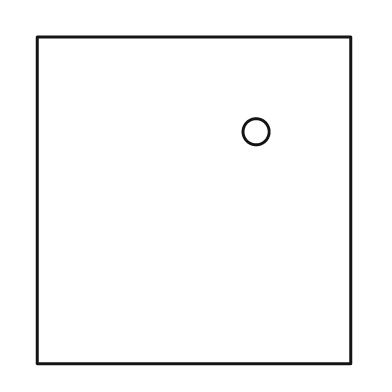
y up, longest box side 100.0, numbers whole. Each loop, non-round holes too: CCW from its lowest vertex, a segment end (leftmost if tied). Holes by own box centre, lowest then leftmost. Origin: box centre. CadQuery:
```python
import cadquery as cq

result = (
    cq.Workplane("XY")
    .moveTo(-48.0, -50.0)
    .lineTo(48.0, -50.0)
    .lineTo(48.0, 50.0)
    .lineTo(-48.0, 50.0)
    .close()
    .moveTo(19.0, 21.0)
    .circle(4.0)
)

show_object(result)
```